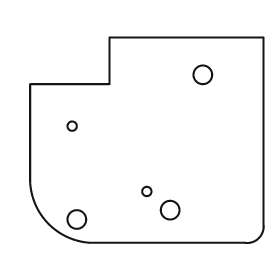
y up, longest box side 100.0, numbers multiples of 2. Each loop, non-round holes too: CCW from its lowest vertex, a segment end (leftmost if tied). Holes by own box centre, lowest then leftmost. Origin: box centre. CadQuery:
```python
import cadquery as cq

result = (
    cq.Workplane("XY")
    .moveTo(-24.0, -44.0)
    .lineTo(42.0, -44.0)
    .threePointArc((48.0, -42.0), (50.0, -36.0))
    .lineTo(50.0, 44.0)
    .lineTo(-16.0, 44.0)
    .lineTo(-16.0, 24.0)
    .lineTo(-50.0, 24.0)
    .lineTo(-50.0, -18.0)
    .threePointArc((-42.0, -36.0), (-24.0, -44.0))
    .close()
    .moveTo(-30.0, -34.0)
    .circle(4.0)
    .moveTo(10.0, -30.0)
    .circle(4.0)
    .moveTo(0.0, -22.0)
    .circle(2.0)
    .moveTo(-32.0, 6.0)
    .circle(2.0)
    .moveTo(24.0, 28.0)
    .circle(4.0)
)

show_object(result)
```